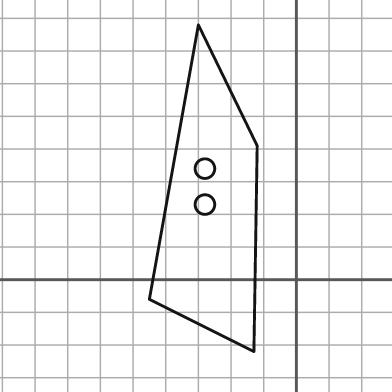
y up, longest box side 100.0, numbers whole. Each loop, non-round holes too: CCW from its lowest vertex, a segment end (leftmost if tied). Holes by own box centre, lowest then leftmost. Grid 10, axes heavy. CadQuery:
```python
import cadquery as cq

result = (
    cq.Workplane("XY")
    .moveTo(-13.0, -22.0)
    .lineTo(-12.0, 41.0)
    .lineTo(-30.0, 78.0)
    .lineTo(-45.0, -6.0)
    .close()
    .moveTo(-28.0, 23.0)
    .circle(3.0)
    .moveTo(-28.0, 34.0)
    .circle(3.0)
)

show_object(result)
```